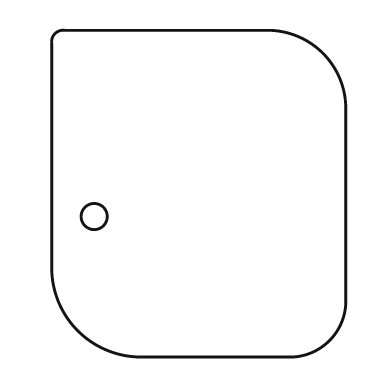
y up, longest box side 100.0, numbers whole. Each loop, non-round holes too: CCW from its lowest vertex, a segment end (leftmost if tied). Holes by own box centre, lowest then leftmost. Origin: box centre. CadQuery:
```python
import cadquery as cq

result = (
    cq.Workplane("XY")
    .moveTo(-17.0, -50.0)
    .lineTo(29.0, -50.0)
    .threePointArc((40.0, -45.0), (45.0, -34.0))
    .lineTo(45.0, 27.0)
    .threePointArc((38.0, 43.0), (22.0, 50.0))
    .lineTo(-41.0, 50.0)
    .threePointArc((-44.0, 49.0), (-45.0, 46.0))
    .lineTo(-45.0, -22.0)
    .threePointArc((-37.0, -42.0), (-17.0, -50.0))
    .close()
    .moveTo(-32.0, -7.0)
    .circle(4.0)
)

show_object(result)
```